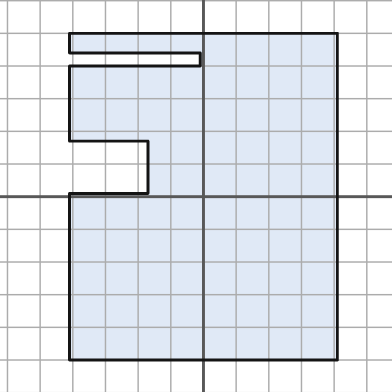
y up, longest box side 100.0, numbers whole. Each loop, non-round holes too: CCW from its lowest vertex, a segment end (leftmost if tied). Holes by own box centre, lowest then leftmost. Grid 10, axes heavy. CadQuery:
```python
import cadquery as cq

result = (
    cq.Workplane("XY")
    .moveTo(-41.0, -50.0)
    .lineTo(41.0, -50.0)
    .lineTo(41.0, 50.0)
    .lineTo(-41.0, 50.0)
    .lineTo(-41.0, 44.0)
    .lineTo(-1.0, 44.0)
    .lineTo(-1.0, 40.0)
    .lineTo(-41.0, 40.0)
    .lineTo(-41.0, 17.0)
    .lineTo(-17.0, 17.0)
    .lineTo(-17.0, 1.0)
    .lineTo(-41.0, 1.0)
    .close()
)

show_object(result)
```